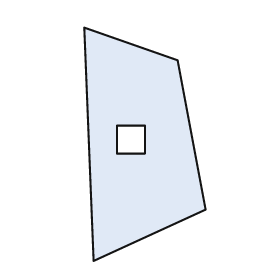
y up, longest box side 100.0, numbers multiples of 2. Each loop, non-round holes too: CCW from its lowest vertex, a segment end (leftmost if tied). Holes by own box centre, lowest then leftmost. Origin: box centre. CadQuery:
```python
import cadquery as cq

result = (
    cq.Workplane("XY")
    .moveTo(-22.0, -50.0)
    .lineTo(26.0, -28.0)
    .lineTo(14.0, 36.0)
    .lineTo(-26.0, 50.0)
    .close()
    .moveTo(-12.0, -4.0)
    .lineTo(0.0, -4.0)
    .lineTo(0.0, 8.0)
    .lineTo(-12.0, 8.0)
    .close()
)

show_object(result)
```